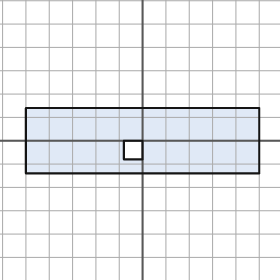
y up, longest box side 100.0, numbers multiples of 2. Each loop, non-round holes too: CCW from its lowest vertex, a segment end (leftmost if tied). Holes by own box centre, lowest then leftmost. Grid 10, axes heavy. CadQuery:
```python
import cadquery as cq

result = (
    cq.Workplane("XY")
    .moveTo(-50.0, -14.0)
    .lineTo(50.0, -14.0)
    .lineTo(50.0, 14.0)
    .lineTo(-50.0, 14.0)
    .close()
    .moveTo(-8.0, -8.0)
    .lineTo(0.0, -8.0)
    .lineTo(0.0, 0.0)
    .lineTo(-8.0, 0.0)
    .close()
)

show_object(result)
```